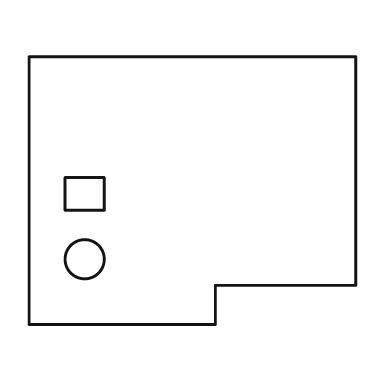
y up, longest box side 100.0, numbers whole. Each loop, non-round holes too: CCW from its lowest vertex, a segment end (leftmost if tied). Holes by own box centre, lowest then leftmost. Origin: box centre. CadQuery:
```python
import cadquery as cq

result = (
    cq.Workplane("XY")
    .moveTo(-50.0, -41.0)
    .lineTo(7.0, -41.0)
    .lineTo(7.0, -29.0)
    .lineTo(50.0, -29.0)
    .lineTo(50.0, 41.0)
    .lineTo(-50.0, 41.0)
    .close()
    .moveTo(-33.0, -21.0)
    .circle(6.0)
    .moveTo(-39.0, -6.0)
    .lineTo(-27.0, -6.0)
    .lineTo(-27.0, 4.0)
    .lineTo(-39.0, 4.0)
    .close()
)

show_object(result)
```